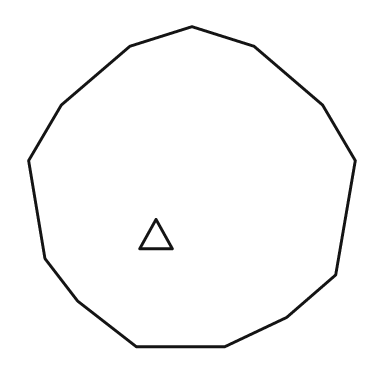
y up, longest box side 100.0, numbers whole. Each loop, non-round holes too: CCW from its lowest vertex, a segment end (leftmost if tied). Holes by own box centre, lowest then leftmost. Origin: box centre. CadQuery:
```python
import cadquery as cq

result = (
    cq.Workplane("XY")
    .moveTo(-17.0, -49.0)
    .lineTo(10.0, -49.0)
    .lineTo(29.0, -40.0)
    .lineTo(44.0, -27.0)
    .lineTo(50.0, 8.0)
    .lineTo(40.0, 25.0)
    .lineTo(19.0, 43.0)
    .lineTo(0.0, 49.0)
    .lineTo(-19.0, 43.0)
    .lineTo(-40.0, 25.0)
    .lineTo(-50.0, 8.0)
    .lineTo(-45.0, -22.0)
    .lineTo(-35.0, -35.0)
    .close()
    .moveTo(-16.0, -19.0)
    .lineTo(-6.0, -19.0)
    .lineTo(-11.0, -10.0)
    .close()
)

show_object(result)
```